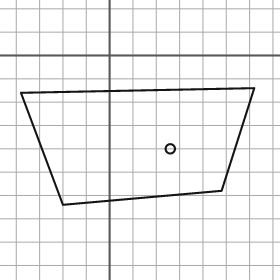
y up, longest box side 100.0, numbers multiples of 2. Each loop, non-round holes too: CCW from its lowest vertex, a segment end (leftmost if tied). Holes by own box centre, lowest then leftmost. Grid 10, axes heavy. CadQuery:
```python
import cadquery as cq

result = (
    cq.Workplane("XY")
    .moveTo(-20.0, -64.0)
    .lineTo(48.0, -58.0)
    .lineTo(62.0, -14.0)
    .lineTo(-38.0, -16.0)
    .close()
    .moveTo(26.0, -40.0)
    .circle(2.0)
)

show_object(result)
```